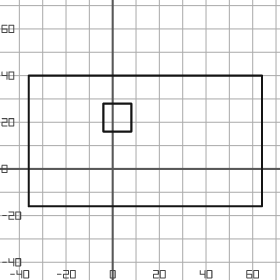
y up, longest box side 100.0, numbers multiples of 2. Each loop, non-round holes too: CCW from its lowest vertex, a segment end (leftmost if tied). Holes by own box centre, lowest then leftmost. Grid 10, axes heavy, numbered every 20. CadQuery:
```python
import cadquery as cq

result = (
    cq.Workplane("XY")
    .moveTo(-36.0, -16.0)
    .lineTo(64.0, -16.0)
    .lineTo(64.0, 40.0)
    .lineTo(-36.0, 40.0)
    .close()
    .moveTo(-4.0, 16.0)
    .lineTo(8.0, 16.0)
    .lineTo(8.0, 28.0)
    .lineTo(-4.0, 28.0)
    .close()
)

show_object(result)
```